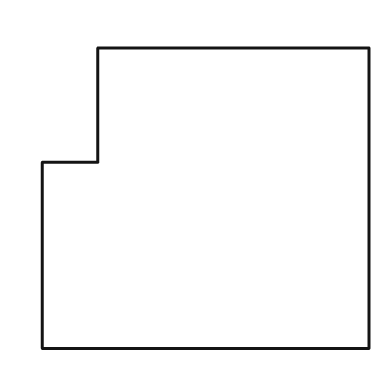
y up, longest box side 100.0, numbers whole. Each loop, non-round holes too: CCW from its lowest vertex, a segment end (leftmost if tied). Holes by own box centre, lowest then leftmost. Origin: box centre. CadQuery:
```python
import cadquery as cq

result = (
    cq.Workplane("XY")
    .moveTo(-50.0, -46.0)
    .lineTo(50.0, -46.0)
    .lineTo(50.0, 46.0)
    .lineTo(-33.0, 46.0)
    .lineTo(-33.0, 11.0)
    .lineTo(-50.0, 11.0)
    .close()
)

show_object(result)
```